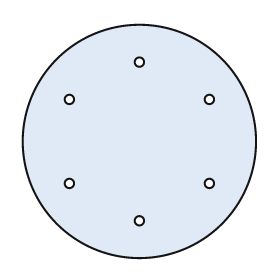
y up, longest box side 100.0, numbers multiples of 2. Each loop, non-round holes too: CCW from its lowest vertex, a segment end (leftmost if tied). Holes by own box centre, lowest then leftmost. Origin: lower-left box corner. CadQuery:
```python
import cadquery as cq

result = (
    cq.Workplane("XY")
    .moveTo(50.0, 50.0)
    .circle(50.0)
    .moveTo(50.0, 16.0)
    .circle(2.0)
    .moveTo(20.0, 32.0)
    .circle(2.0)
    .moveTo(80.0, 32.0)
    .circle(2.0)
    .moveTo(20.0, 68.0)
    .circle(2.0)
    .moveTo(80.0, 68.0)
    .circle(2.0)
    .moveTo(50.0, 84.0)
    .circle(2.0)
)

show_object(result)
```